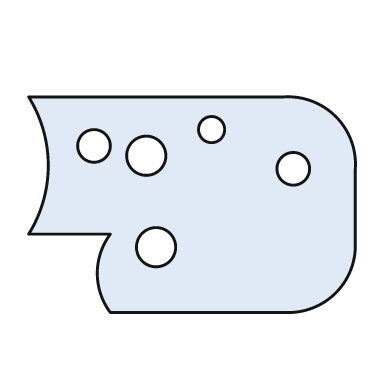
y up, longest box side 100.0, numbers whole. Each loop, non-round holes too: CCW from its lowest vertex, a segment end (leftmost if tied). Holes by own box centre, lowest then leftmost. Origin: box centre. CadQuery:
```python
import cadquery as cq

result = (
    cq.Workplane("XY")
    .moveTo(-25.0, -33.0)
    .lineTo(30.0, -33.0)
    .threePointArc((44.0, -27.0), (50.0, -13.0))
    .lineTo(50.0, 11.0)
    .threePointArc((44.0, 27.0), (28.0, 33.0))
    .lineTo(-50.0, 33.0)
    .threePointArc((-44.0, 12.0), (-50.0, -9.0))
    .lineTo(-25.0, -9.0)
    .threePointArc((-29.0, -21.0), (-25.0, -33.0))
    .close()
    .moveTo(-11.0, -13.0)
    .circle(6.0)
    .moveTo(31.0, 11.0)
    .circle(5.0)
    .moveTo(-14.0, 15.0)
    .circle(6.0)
    .moveTo(-30.0, 18.0)
    .circle(5.0)
    .moveTo(6.0, 23.0)
    .circle(4.0)
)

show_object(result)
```